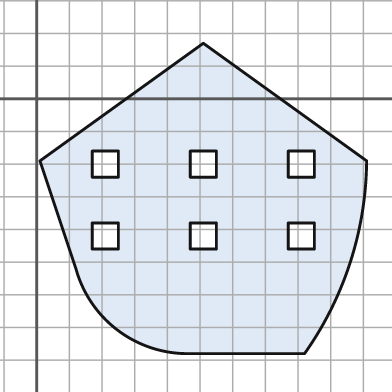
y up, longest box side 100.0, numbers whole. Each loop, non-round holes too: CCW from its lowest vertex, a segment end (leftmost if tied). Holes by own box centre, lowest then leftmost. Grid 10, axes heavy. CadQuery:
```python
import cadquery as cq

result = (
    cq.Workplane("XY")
    .moveTo(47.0, -78.0)
    .lineTo(82.0, -78.0)
    .threePointArc((96.0, -50.0), (101.0, -19.0))
    .lineTo(51.0, 17.0)
    .lineTo(1.0, -19.0)
    .lineTo(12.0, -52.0)
    .threePointArc((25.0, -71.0), (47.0, -78.0))
    .close()
    .moveTo(17.0, -46.0)
    .lineTo(25.0, -46.0)
    .lineTo(25.0, -38.0)
    .lineTo(17.0, -38.0)
    .close()
    .moveTo(47.0, -46.0)
    .lineTo(55.0, -46.0)
    .lineTo(55.0, -38.0)
    .lineTo(47.0, -38.0)
    .close()
    .moveTo(77.0, -46.0)
    .lineTo(85.0, -46.0)
    .lineTo(85.0, -38.0)
    .lineTo(77.0, -38.0)
    .close()
    .moveTo(17.0, -24.0)
    .lineTo(25.0, -24.0)
    .lineTo(25.0, -16.0)
    .lineTo(17.0, -16.0)
    .close()
    .moveTo(47.0, -24.0)
    .lineTo(55.0, -24.0)
    .lineTo(55.0, -16.0)
    .lineTo(47.0, -16.0)
    .close()
    .moveTo(77.0, -24.0)
    .lineTo(85.0, -24.0)
    .lineTo(85.0, -16.0)
    .lineTo(77.0, -16.0)
    .close()
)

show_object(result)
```